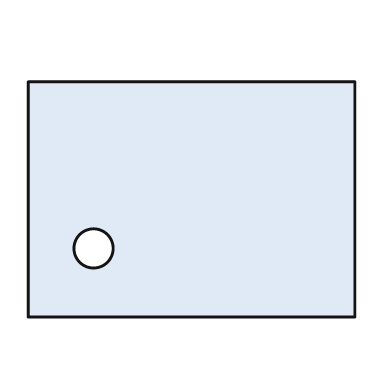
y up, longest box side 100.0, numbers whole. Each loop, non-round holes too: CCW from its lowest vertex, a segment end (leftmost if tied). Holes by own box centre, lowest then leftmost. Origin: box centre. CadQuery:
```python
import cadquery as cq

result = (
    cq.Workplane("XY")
    .moveTo(-50.0, -36.0)
    .lineTo(50.0, -36.0)
    .lineTo(50.0, 36.0)
    .lineTo(-50.0, 36.0)
    .close()
    .moveTo(-30.0, -15.0)
    .circle(6.0)
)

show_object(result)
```